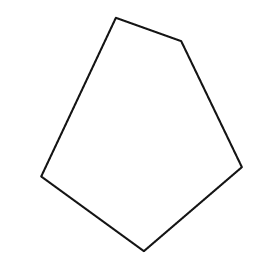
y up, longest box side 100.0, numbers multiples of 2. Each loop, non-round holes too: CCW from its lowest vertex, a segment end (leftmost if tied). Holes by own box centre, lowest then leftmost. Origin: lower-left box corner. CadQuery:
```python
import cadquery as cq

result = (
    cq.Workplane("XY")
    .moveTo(44.0, 0.0)
    .lineTo(86.0, 36.0)
    .lineTo(60.0, 90.0)
    .lineTo(32.0, 100.0)
    .lineTo(0.0, 32.0)
    .close()
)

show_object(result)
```